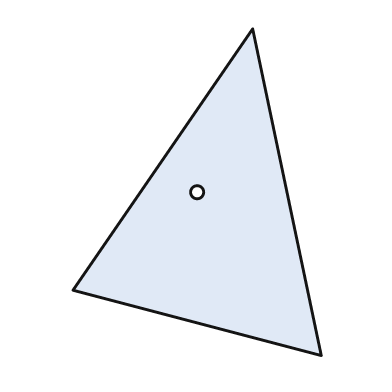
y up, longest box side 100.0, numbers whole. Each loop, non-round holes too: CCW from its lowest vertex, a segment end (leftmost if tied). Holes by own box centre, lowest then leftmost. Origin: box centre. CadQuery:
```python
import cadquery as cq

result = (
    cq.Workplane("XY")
    .moveTo(38.0, -50.0)
    .lineTo(17.0, 50.0)
    .lineTo(-38.0, -30.0)
    .close()
    .moveTo(0.0, 0.0)
    .circle(2.0)
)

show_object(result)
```